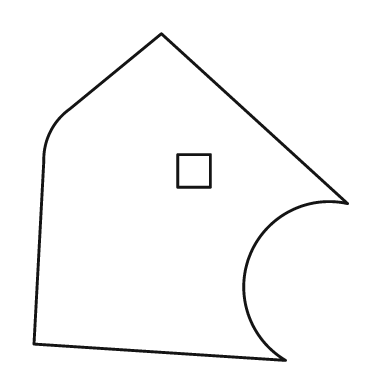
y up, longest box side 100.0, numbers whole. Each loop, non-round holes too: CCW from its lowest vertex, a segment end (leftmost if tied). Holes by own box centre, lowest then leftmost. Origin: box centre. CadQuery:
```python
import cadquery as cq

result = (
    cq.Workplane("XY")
    .moveTo(29.0, -50.0)
    .threePointArc((18.0, -18.0), (48.0, -2.0))
    .lineTo(-9.0, 50.0)
    .lineTo(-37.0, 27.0)
    .threePointArc((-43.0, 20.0), (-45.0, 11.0))
    .lineTo(-48.0, -45.0)
    .close()
    .moveTo(-4.0, 3.0)
    .lineTo(6.0, 3.0)
    .lineTo(6.0, 13.0)
    .lineTo(-4.0, 13.0)
    .close()
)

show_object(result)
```